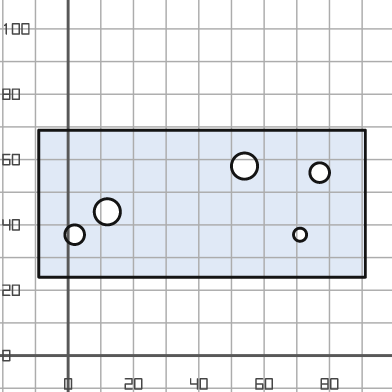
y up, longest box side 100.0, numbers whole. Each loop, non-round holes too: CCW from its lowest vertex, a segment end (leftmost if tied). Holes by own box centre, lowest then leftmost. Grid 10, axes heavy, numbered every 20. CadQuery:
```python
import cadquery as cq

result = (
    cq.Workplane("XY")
    .moveTo(-9.0, 24.0)
    .lineTo(91.0, 24.0)
    .lineTo(91.0, 69.0)
    .lineTo(-9.0, 69.0)
    .close()
    .moveTo(2.0, 37.0)
    .circle(3.0)
    .moveTo(71.0, 37.0)
    .circle(2.0)
    .moveTo(12.0, 44.0)
    .circle(4.0)
    .moveTo(77.0, 56.0)
    .circle(3.0)
    .moveTo(54.0, 58.0)
    .circle(4.0)
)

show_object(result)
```